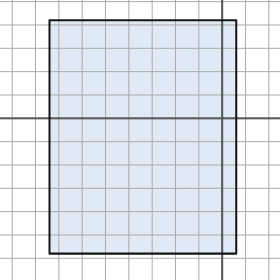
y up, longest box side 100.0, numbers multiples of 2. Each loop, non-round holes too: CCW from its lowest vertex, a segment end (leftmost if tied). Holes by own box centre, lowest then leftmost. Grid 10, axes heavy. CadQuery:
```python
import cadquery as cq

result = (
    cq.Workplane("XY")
    .moveTo(-74.0, -58.0)
    .lineTo(6.0, -58.0)
    .lineTo(6.0, 42.0)
    .lineTo(-74.0, 42.0)
    .close()
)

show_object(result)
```